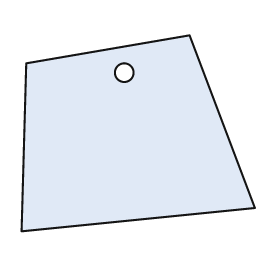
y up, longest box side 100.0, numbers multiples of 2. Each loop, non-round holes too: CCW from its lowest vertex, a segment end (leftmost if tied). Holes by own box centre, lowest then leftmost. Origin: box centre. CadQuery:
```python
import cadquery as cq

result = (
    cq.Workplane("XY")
    .moveTo(-50.0, -42.0)
    .lineTo(50.0, -32.0)
    .lineTo(22.0, 42.0)
    .lineTo(-48.0, 30.0)
    .close()
    .moveTo(-6.0, 26.0)
    .circle(4.0)
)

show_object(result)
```